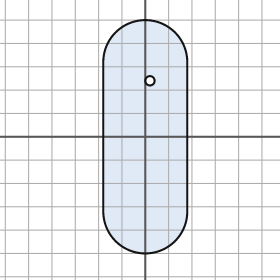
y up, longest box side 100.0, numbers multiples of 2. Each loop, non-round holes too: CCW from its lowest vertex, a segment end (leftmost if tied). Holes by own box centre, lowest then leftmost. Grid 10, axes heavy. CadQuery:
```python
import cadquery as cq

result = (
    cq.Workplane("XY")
    .moveTo(-18.0, -32.0)
    .threePointArc((0.0, -50.0), (18.0, -32.0))
    .lineTo(18.0, 32.0)
    .threePointArc((0.0, 50.0), (-18.0, 32.0))
    .close()
    .moveTo(2.0, 24.0)
    .circle(2.0)
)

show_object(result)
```